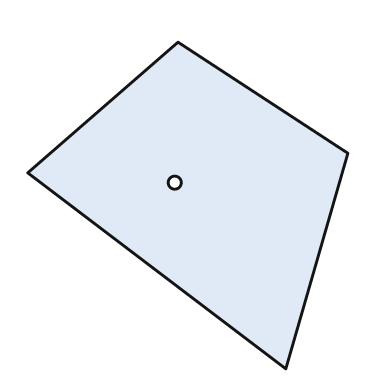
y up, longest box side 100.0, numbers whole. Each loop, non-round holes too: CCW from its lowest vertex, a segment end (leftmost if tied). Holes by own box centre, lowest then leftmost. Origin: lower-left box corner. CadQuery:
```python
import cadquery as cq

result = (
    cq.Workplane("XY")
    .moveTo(79.0, 0.0)
    .lineTo(98.0, 66.0)
    .lineTo(46.0, 100.0)
    .lineTo(0.0, 60.0)
    .close()
    .moveTo(45.0, 57.0)
    .circle(2.0)
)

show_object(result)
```